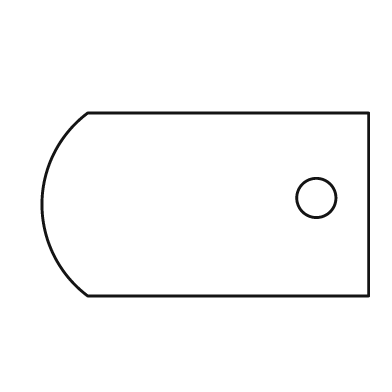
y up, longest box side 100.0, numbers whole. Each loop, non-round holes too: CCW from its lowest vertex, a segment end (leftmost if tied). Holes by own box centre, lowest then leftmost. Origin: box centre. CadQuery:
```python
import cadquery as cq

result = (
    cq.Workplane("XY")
    .moveTo(-36.0, -28.0)
    .lineTo(50.0, -28.0)
    .lineTo(50.0, 28.0)
    .lineTo(-36.0, 28.0)
    .threePointArc((-50.0, 0.0), (-36.0, -28.0))
    .close()
    .moveTo(34.0, 2.0)
    .circle(6.0)
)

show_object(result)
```